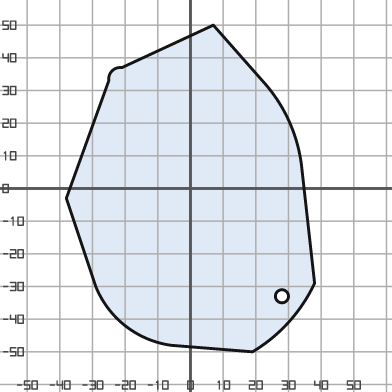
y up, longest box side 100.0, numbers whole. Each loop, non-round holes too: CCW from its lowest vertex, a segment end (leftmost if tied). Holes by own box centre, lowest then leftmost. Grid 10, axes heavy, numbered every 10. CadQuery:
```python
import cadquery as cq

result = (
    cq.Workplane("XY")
    .moveTo(19.0, -50.0)
    .threePointArc((30.0, -41.0), (38.0, -29.0))
    .lineTo(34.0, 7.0)
    .threePointArc((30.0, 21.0), (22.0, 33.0))
    .lineTo(7.0, 50.0)
    .lineTo(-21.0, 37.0)
    .threePointArc((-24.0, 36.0), (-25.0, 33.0))
    .lineTo(-38.0, -3.0)
    .lineTo(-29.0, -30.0)
    .threePointArc((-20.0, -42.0), (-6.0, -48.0))
    .close()
    .moveTo(28.0, -33.0)
    .circle(2.0)
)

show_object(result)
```